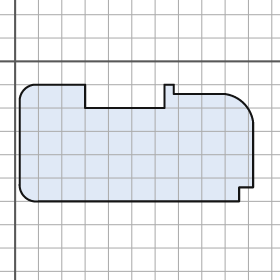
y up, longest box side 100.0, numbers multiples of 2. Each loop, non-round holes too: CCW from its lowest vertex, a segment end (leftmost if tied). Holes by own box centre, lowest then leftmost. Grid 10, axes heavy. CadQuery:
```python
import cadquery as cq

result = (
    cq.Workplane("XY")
    .moveTo(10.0, -60.0)
    .lineTo(96.0, -60.0)
    .lineTo(96.0, -54.0)
    .lineTo(102.0, -54.0)
    .lineTo(102.0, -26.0)
    .threePointArc((98.0, -18.0), (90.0, -14.0))
    .lineTo(68.0, -14.0)
    .lineTo(68.0, -10.0)
    .lineTo(64.0, -10.0)
    .lineTo(64.0, -20.0)
    .lineTo(30.0, -20.0)
    .lineTo(30.0, -10.0)
    .lineTo(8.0, -10.0)
    .threePointArc((4.0, -12.0), (2.0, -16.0))
    .lineTo(2.0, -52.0)
    .threePointArc((4.0, -58.0), (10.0, -60.0))
    .close()
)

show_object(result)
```